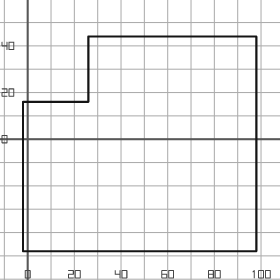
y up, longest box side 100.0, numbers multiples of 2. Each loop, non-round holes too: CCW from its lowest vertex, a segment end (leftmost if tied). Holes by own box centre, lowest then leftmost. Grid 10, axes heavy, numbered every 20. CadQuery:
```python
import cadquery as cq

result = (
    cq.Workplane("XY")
    .moveTo(-2.0, -48.0)
    .lineTo(98.0, -48.0)
    .lineTo(98.0, 44.0)
    .lineTo(26.0, 44.0)
    .lineTo(26.0, 16.0)
    .lineTo(-2.0, 16.0)
    .close()
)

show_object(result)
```